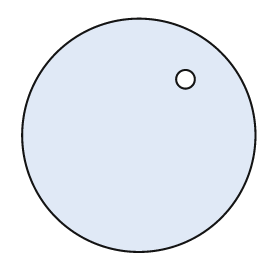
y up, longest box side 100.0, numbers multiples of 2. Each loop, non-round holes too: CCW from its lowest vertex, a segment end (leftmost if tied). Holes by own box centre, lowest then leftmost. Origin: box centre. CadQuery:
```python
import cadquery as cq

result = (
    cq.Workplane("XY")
    .moveTo(0.0, 0.0)
    .circle(50.0)
    .moveTo(20.0, 24.0)
    .circle(4.0)
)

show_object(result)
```